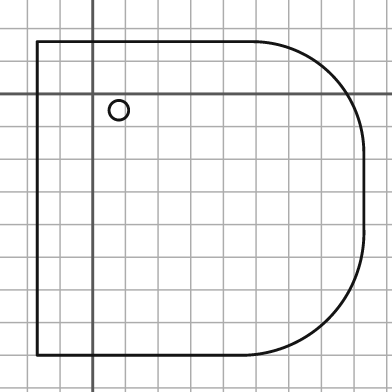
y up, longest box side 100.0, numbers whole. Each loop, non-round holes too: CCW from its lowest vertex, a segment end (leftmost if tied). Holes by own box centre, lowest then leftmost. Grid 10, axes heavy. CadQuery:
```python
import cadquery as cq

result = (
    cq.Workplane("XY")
    .moveTo(-17.0, -80.0)
    .lineTo(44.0, -80.0)
    .threePointArc((72.0, -69.0), (83.0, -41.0))
    .lineTo(83.0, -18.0)
    .threePointArc((73.0, 6.0), (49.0, 16.0))
    .lineTo(-17.0, 16.0)
    .close()
    .moveTo(8.0, -5.0)
    .circle(3.0)
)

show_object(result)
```